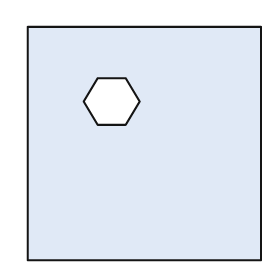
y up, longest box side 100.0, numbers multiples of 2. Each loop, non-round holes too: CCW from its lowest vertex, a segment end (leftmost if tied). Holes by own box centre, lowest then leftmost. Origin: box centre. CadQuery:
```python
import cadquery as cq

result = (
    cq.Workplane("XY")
    .moveTo(-50.0, -50.0)
    .lineTo(50.0, -50.0)
    .lineTo(50.0, 50.0)
    .lineTo(-50.0, 50.0)
    .close()
    .moveTo(-20.0, 8.0)
    .lineTo(-8.0, 8.0)
    .lineTo(-2.0, 18.0)
    .lineTo(-8.0, 28.0)
    .lineTo(-20.0, 28.0)
    .lineTo(-26.0, 18.0)
    .close()
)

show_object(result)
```